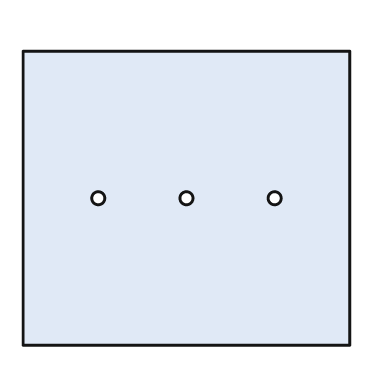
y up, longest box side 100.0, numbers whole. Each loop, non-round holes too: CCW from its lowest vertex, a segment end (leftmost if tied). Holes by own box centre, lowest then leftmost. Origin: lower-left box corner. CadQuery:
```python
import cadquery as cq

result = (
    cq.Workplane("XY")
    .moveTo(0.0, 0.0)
    .lineTo(100.0, 0.0)
    .lineTo(100.0, 90.0)
    .lineTo(0.0, 90.0)
    .close()
    .moveTo(23.0, 45.0)
    .circle(2.0)
    .moveTo(50.0, 45.0)
    .circle(2.0)
    .moveTo(77.0, 45.0)
    .circle(2.0)
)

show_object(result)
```